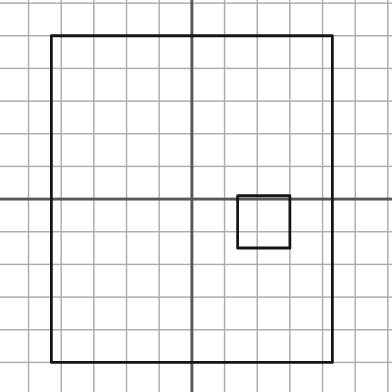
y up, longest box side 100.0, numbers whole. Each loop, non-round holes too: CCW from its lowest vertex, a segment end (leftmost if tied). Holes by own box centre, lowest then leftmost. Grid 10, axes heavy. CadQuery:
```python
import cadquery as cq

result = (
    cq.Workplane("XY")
    .moveTo(-43.0, -50.0)
    .lineTo(43.0, -50.0)
    .lineTo(43.0, 50.0)
    .lineTo(-43.0, 50.0)
    .close()
    .moveTo(14.0, -15.0)
    .lineTo(30.0, -15.0)
    .lineTo(30.0, 1.0)
    .lineTo(14.0, 1.0)
    .close()
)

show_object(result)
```